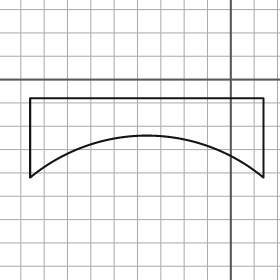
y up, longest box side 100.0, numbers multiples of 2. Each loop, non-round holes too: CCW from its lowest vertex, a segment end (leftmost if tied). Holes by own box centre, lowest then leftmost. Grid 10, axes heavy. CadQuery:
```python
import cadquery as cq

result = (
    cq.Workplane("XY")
    .moveTo(-86.0, -42.0)
    .threePointArc((-36.0, -24.0), (14.0, -42.0))
    .lineTo(14.0, -8.0)
    .lineTo(-86.0, -8.0)
    .close()
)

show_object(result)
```